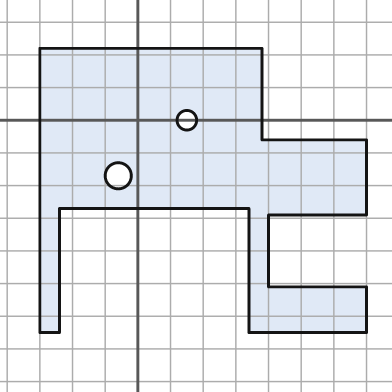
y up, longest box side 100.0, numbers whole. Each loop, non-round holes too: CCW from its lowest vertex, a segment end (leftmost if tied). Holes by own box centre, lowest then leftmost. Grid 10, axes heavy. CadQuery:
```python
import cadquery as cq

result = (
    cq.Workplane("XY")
    .moveTo(-30.0, -65.0)
    .lineTo(-24.0, -65.0)
    .lineTo(-24.0, -27.0)
    .lineTo(34.0, -27.0)
    .lineTo(34.0, -65.0)
    .lineTo(70.0, -65.0)
    .lineTo(70.0, -51.0)
    .lineTo(40.0, -51.0)
    .lineTo(40.0, -29.0)
    .lineTo(70.0, -29.0)
    .lineTo(70.0, -6.0)
    .lineTo(38.0, -6.0)
    .lineTo(38.0, 22.0)
    .lineTo(-30.0, 22.0)
    .close()
    .moveTo(-6.0, -17.0)
    .circle(4.0)
    .moveTo(15.0, 0.0)
    .circle(3.0)
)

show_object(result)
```